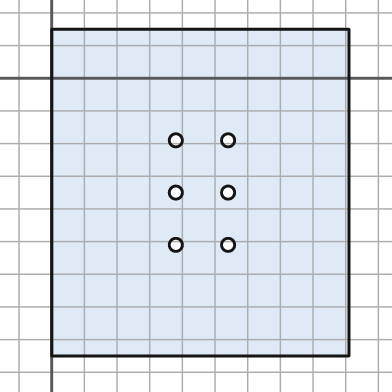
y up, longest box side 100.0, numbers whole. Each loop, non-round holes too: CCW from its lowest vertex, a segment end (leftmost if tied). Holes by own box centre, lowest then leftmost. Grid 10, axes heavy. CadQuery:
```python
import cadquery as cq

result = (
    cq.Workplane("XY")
    .moveTo(0.0, -85.0)
    .lineTo(91.0, -85.0)
    .lineTo(91.0, 15.0)
    .lineTo(0.0, 15.0)
    .close()
    .moveTo(38.0, -51.0)
    .circle(2.0)
    .moveTo(54.0, -51.0)
    .circle(2.0)
    .moveTo(38.0, -35.0)
    .circle(2.0)
    .moveTo(54.0, -35.0)
    .circle(2.0)
    .moveTo(38.0, -19.0)
    .circle(2.0)
    .moveTo(54.0, -19.0)
    .circle(2.0)
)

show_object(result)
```